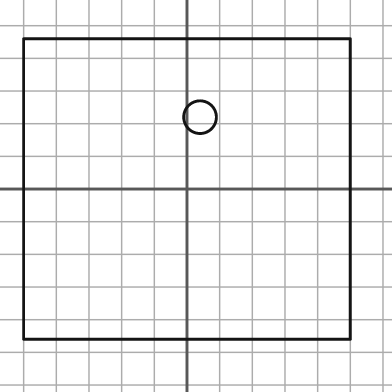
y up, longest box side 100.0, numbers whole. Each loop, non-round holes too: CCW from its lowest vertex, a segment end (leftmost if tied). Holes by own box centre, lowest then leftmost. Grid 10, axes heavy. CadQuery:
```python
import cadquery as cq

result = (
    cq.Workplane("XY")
    .moveTo(-50.0, -46.0)
    .lineTo(50.0, -46.0)
    .lineTo(50.0, 46.0)
    .lineTo(-50.0, 46.0)
    .close()
    .moveTo(4.0, 22.0)
    .circle(5.0)
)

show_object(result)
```